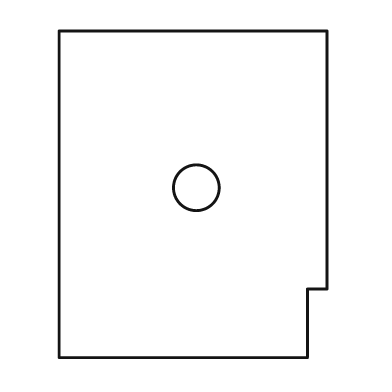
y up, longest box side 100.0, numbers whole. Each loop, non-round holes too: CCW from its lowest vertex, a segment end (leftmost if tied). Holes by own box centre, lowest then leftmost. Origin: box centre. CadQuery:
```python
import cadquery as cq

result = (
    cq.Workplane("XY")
    .moveTo(-41.0, -50.0)
    .lineTo(35.0, -50.0)
    .lineTo(35.0, -29.0)
    .lineTo(41.0, -29.0)
    .lineTo(41.0, 50.0)
    .lineTo(-41.0, 50.0)
    .close()
    .moveTo(1.0, 2.0)
    .circle(7.0)
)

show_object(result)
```